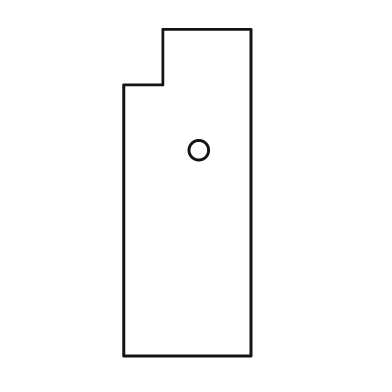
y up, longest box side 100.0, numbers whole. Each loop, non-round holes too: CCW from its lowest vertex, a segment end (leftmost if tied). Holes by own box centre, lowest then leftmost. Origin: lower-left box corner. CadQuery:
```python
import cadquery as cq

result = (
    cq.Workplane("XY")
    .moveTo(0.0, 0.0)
    .lineTo(39.0, 0.0)
    .lineTo(39.0, 100.0)
    .lineTo(12.0, 100.0)
    .lineTo(12.0, 83.0)
    .lineTo(0.0, 83.0)
    .close()
    .moveTo(23.0, 63.0)
    .circle(3.0)
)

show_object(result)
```